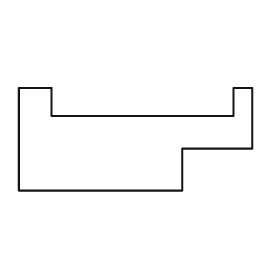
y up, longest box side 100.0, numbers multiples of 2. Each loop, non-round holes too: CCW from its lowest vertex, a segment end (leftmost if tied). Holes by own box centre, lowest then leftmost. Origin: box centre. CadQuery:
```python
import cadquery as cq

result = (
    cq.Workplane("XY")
    .moveTo(-50.0, -22.0)
    .lineTo(20.0, -22.0)
    .lineTo(20.0, -4.0)
    .lineTo(50.0, -4.0)
    .lineTo(50.0, 22.0)
    .lineTo(42.0, 22.0)
    .lineTo(42.0, 10.0)
    .lineTo(-36.0, 10.0)
    .lineTo(-36.0, 22.0)
    .lineTo(-50.0, 22.0)
    .close()
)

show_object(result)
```